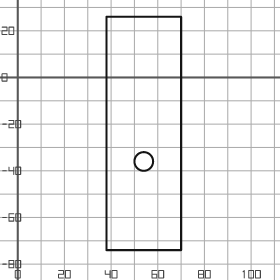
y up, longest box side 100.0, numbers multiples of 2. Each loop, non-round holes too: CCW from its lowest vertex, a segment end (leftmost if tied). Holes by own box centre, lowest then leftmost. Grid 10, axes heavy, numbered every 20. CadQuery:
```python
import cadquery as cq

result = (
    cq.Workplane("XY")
    .moveTo(38.0, -74.0)
    .lineTo(70.0, -74.0)
    .lineTo(70.0, 26.0)
    .lineTo(38.0, 26.0)
    .close()
    .moveTo(54.0, -36.0)
    .circle(4.0)
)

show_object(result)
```